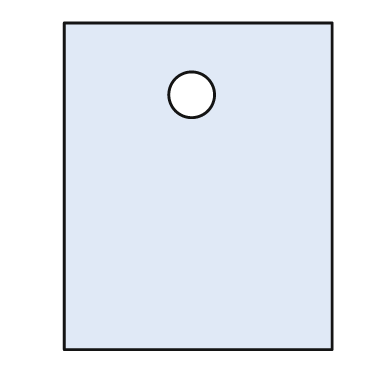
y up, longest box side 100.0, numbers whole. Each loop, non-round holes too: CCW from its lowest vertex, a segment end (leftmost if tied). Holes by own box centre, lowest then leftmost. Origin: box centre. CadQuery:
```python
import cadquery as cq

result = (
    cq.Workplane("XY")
    .moveTo(-41.0, -50.0)
    .lineTo(41.0, -50.0)
    .lineTo(41.0, 50.0)
    .lineTo(-41.0, 50.0)
    .close()
    .moveTo(-2.0, 28.0)
    .circle(7.0)
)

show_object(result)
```